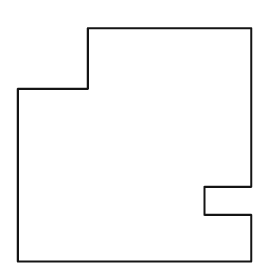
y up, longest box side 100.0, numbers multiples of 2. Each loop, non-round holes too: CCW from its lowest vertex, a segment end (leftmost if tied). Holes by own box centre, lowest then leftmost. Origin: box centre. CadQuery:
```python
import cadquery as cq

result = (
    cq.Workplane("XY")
    .moveTo(-50.0, -50.0)
    .lineTo(50.0, -50.0)
    .lineTo(50.0, -30.0)
    .lineTo(30.0, -30.0)
    .lineTo(30.0, -18.0)
    .lineTo(50.0, -18.0)
    .lineTo(50.0, 50.0)
    .lineTo(-20.0, 50.0)
    .lineTo(-20.0, 24.0)
    .lineTo(-50.0, 24.0)
    .close()
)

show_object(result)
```